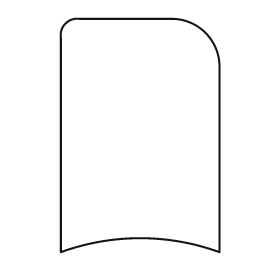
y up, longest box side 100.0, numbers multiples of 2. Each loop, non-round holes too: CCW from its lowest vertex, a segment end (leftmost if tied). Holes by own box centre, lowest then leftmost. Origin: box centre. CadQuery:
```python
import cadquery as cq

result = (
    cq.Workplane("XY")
    .moveTo(-34.0, -50.0)
    .threePointArc((0.0, -44.0), (34.0, -50.0))
    .lineTo(34.0, 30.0)
    .threePointArc((28.0, 44.0), (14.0, 50.0))
    .lineTo(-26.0, 50.0)
    .threePointArc((-32.0, 48.0), (-34.0, 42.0))
    .close()
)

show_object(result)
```